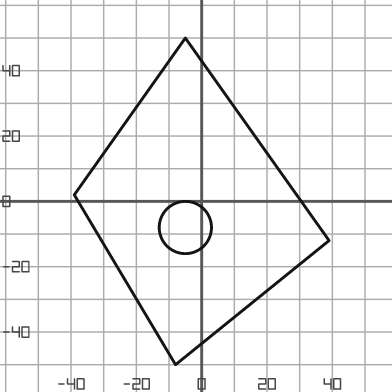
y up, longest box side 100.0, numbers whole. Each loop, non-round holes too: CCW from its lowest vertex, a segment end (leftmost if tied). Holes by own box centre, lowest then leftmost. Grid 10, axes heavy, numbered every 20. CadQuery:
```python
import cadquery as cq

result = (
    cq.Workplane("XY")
    .moveTo(-8.0, -50.0)
    .lineTo(39.0, -12.0)
    .lineTo(-5.0, 50.0)
    .lineTo(-39.0, 2.0)
    .close()
    .moveTo(-5.0, -8.0)
    .circle(8.0)
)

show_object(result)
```